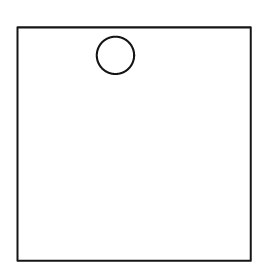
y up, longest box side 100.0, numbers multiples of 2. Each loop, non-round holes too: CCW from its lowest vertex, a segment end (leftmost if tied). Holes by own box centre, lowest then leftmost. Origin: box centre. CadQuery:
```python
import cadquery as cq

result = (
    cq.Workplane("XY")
    .moveTo(-50.0, -50.0)
    .lineTo(50.0, -50.0)
    .lineTo(50.0, 50.0)
    .lineTo(-50.0, 50.0)
    .close()
    .moveTo(-8.0, 38.0)
    .circle(8.0)
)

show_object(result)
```